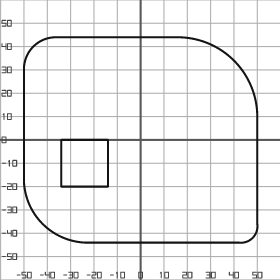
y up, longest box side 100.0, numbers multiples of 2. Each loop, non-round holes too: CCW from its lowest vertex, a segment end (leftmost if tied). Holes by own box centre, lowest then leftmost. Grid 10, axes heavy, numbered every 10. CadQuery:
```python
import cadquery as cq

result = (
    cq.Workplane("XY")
    .moveTo(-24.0, -44.0)
    .lineTo(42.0, -44.0)
    .threePointArc((48.0, -42.0), (50.0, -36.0))
    .lineTo(50.0, 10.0)
    .threePointArc((40.0, 34.0), (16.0, 44.0))
    .lineTo(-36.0, 44.0)
    .threePointArc((-46.0, 40.0), (-50.0, 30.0))
    .lineTo(-50.0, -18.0)
    .threePointArc((-42.0, -36.0), (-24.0, -44.0))
    .close()
    .moveTo(-34.0, -20.0)
    .lineTo(-14.0, -20.0)
    .lineTo(-14.0, 0.0)
    .lineTo(-34.0, 0.0)
    .close()
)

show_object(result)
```